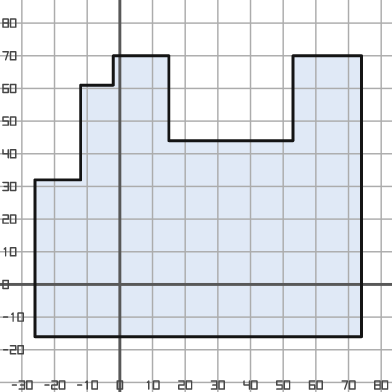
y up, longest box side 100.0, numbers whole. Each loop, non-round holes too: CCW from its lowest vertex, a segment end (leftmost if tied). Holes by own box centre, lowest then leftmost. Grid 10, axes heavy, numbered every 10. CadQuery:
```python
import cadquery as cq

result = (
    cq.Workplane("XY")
    .moveTo(-26.0, -16.0)
    .lineTo(74.0, -16.0)
    .lineTo(74.0, 70.0)
    .lineTo(53.0, 70.0)
    .lineTo(53.0, 44.0)
    .lineTo(15.0, 44.0)
    .lineTo(15.0, 70.0)
    .lineTo(-2.0, 70.0)
    .lineTo(-2.0, 61.0)
    .lineTo(-12.0, 61.0)
    .lineTo(-12.0, 32.0)
    .lineTo(-26.0, 32.0)
    .close()
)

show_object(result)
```